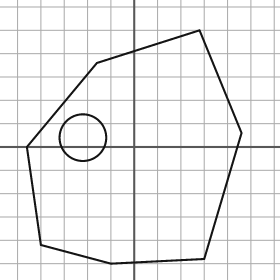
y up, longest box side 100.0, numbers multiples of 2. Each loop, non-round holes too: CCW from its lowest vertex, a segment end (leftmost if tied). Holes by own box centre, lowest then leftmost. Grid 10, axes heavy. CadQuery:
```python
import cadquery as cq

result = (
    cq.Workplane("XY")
    .moveTo(-10.0, -50.0)
    .lineTo(30.0, -48.0)
    .lineTo(46.0, 6.0)
    .lineTo(28.0, 50.0)
    .lineTo(-16.0, 36.0)
    .lineTo(-46.0, 0.0)
    .lineTo(-40.0, -42.0)
    .close()
    .moveTo(-22.0, 4.0)
    .circle(10.0)
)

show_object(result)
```